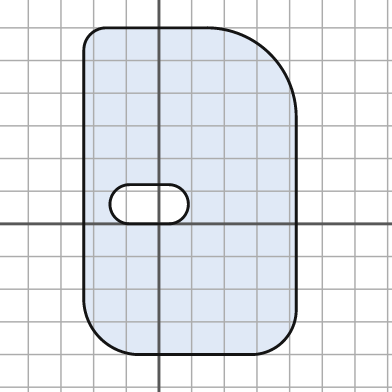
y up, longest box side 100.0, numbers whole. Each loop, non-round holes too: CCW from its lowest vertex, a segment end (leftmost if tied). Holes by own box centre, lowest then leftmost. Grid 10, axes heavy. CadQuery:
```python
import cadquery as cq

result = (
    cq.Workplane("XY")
    .moveTo(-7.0, -40.0)
    .lineTo(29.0, -40.0)
    .threePointArc((38.0, -36.0), (42.0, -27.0))
    .lineTo(42.0, 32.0)
    .threePointArc((34.0, 52.0), (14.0, 60.0))
    .lineTo(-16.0, 60.0)
    .threePointArc((-21.0, 58.0), (-23.0, 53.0))
    .lineTo(-23.0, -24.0)
    .threePointArc((-18.0, -35.0), (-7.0, -40.0))
    .close()
    .moveTo(-9.0, 0.0)
    .lineTo(3.0, 0.0)
    .threePointArc((9.0, 6.0), (3.0, 12.0))
    .lineTo(-9.0, 12.0)
    .threePointArc((-15.0, 6.0), (-9.0, 0.0))
    .close()
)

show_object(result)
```